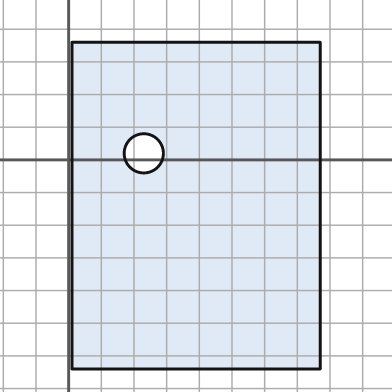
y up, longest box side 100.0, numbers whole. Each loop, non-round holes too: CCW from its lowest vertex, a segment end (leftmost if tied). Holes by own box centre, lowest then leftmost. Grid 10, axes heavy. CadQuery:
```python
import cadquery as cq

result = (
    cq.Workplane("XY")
    .moveTo(1.0, -64.0)
    .lineTo(77.0, -64.0)
    .lineTo(77.0, 36.0)
    .lineTo(1.0, 36.0)
    .close()
    .moveTo(23.0, 2.0)
    .circle(6.0)
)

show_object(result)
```